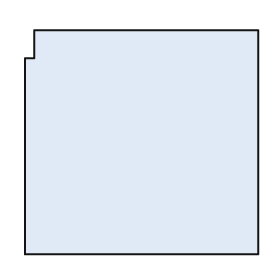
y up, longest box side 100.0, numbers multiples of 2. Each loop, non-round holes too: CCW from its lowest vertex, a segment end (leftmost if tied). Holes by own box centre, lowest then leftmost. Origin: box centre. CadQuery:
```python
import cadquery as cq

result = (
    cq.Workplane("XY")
    .moveTo(-50.0, -48.0)
    .lineTo(50.0, -48.0)
    .lineTo(50.0, 48.0)
    .lineTo(-46.0, 48.0)
    .lineTo(-46.0, 36.0)
    .lineTo(-50.0, 36.0)
    .close()
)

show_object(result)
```